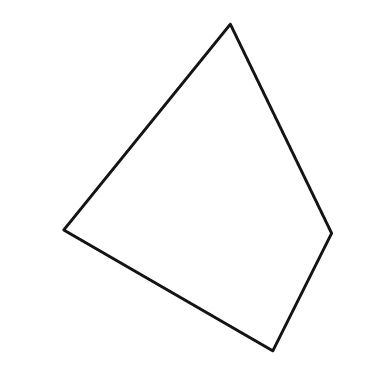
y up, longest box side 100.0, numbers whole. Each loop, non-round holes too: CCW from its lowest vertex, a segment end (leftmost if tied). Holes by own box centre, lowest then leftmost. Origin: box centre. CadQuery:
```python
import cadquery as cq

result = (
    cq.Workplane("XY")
    .moveTo(23.0, -50.0)
    .lineTo(41.0, -14.0)
    .lineTo(10.0, 50.0)
    .lineTo(-41.0, -13.0)
    .close()
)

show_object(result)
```